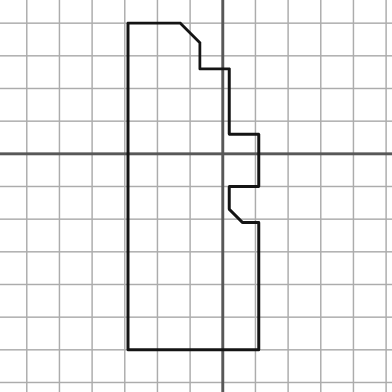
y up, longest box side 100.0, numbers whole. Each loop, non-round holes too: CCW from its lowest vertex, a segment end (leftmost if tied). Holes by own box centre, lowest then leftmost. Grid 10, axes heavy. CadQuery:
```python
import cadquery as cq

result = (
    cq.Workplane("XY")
    .moveTo(-29.0, -60.0)
    .lineTo(11.0, -60.0)
    .lineTo(11.0, -21.0)
    .lineTo(6.0, -21.0)
    .lineTo(2.0, -17.0)
    .lineTo(2.0, -10.0)
    .lineTo(11.0, -10.0)
    .lineTo(11.0, 6.0)
    .lineTo(2.0, 6.0)
    .lineTo(2.0, 26.0)
    .lineTo(-7.0, 26.0)
    .lineTo(-7.0, 34.0)
    .lineTo(-13.0, 40.0)
    .lineTo(-29.0, 40.0)
    .close()
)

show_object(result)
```